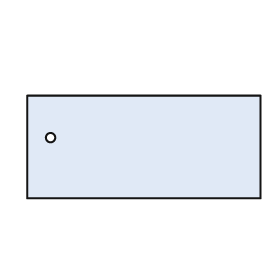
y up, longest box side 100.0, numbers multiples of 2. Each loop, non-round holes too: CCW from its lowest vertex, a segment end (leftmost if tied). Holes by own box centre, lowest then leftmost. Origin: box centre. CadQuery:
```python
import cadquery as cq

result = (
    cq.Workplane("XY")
    .moveTo(-50.0, -22.0)
    .lineTo(50.0, -22.0)
    .lineTo(50.0, 22.0)
    .lineTo(-50.0, 22.0)
    .close()
    .moveTo(-40.0, 4.0)
    .circle(2.0)
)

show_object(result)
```